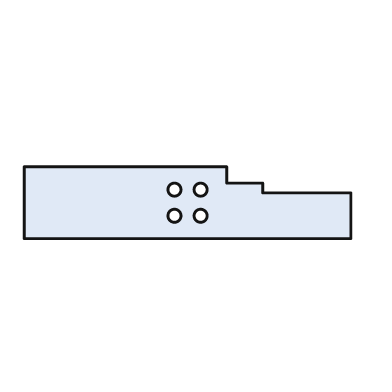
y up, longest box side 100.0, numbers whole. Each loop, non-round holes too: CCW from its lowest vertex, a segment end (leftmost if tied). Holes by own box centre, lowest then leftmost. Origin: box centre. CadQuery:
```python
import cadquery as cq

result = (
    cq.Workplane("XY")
    .moveTo(-50.0, -11.0)
    .lineTo(50.0, -11.0)
    .lineTo(50.0, 3.0)
    .lineTo(23.0, 3.0)
    .lineTo(23.0, 6.0)
    .lineTo(12.0, 6.0)
    .lineTo(12.0, 11.0)
    .lineTo(-50.0, 11.0)
    .close()
    .moveTo(-4.0, -4.0)
    .circle(2.0)
    .moveTo(4.0, -4.0)
    .circle(2.0)
    .moveTo(-4.0, 4.0)
    .circle(2.0)
    .moveTo(4.0, 4.0)
    .circle(2.0)
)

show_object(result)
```